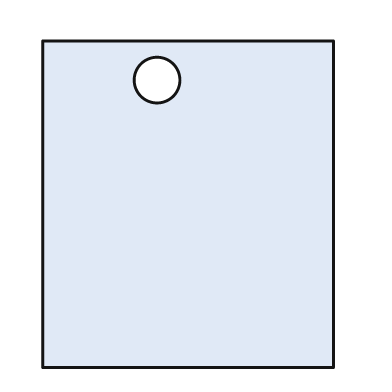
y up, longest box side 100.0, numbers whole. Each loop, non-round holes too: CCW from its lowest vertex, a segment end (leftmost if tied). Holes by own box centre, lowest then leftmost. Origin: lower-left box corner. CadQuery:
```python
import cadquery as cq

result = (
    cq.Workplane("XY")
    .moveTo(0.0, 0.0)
    .lineTo(89.0, 0.0)
    .lineTo(89.0, 100.0)
    .lineTo(0.0, 100.0)
    .close()
    .moveTo(35.0, 88.0)
    .circle(7.0)
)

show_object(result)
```